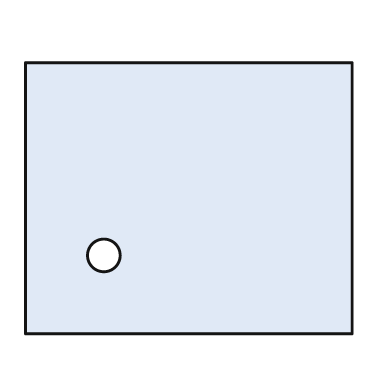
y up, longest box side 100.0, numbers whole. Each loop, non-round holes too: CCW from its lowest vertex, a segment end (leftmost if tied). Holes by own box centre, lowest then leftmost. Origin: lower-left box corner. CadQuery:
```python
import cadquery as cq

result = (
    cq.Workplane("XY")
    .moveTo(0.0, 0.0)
    .lineTo(100.0, 0.0)
    .lineTo(100.0, 83.0)
    .lineTo(0.0, 83.0)
    .close()
    .moveTo(24.0, 24.0)
    .circle(5.0)
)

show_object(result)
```